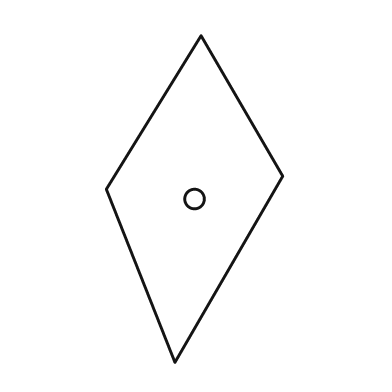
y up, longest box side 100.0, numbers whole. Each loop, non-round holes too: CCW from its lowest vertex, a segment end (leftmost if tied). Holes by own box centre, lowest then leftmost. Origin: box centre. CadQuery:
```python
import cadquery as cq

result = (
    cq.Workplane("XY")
    .moveTo(-6.0, -50.0)
    .lineTo(27.0, 7.0)
    .lineTo(2.0, 50.0)
    .lineTo(-27.0, 3.0)
    .close()
    .moveTo(0.0, 0.0)
    .circle(3.0)
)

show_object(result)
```